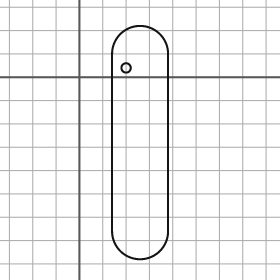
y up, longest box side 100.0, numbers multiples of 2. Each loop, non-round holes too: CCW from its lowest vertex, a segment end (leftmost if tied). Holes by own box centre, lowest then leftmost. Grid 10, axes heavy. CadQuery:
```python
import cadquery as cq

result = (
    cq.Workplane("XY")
    .moveTo(14.0, -66.0)
    .threePointArc((26.0, -78.0), (38.0, -66.0))
    .lineTo(38.0, 10.0)
    .threePointArc((26.0, 22.0), (14.0, 10.0))
    .close()
    .moveTo(20.0, 4.0)
    .circle(2.0)
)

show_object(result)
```